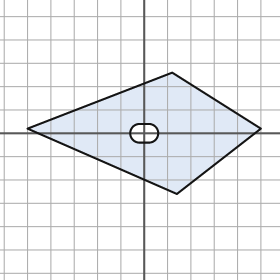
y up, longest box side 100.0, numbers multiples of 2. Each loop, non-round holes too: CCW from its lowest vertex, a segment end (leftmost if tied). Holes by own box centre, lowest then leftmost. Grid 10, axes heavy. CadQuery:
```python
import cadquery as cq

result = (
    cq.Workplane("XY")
    .moveTo(14.0, -26.0)
    .lineTo(50.0, 2.0)
    .lineTo(12.0, 26.0)
    .lineTo(-50.0, 2.0)
    .close()
    .moveTo(-2.0, -4.0)
    .lineTo(2.0, -4.0)
    .threePointArc((6.0, 0.0), (2.0, 4.0))
    .lineTo(-2.0, 4.0)
    .threePointArc((-6.0, 0.0), (-2.0, -4.0))
    .close()
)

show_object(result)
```